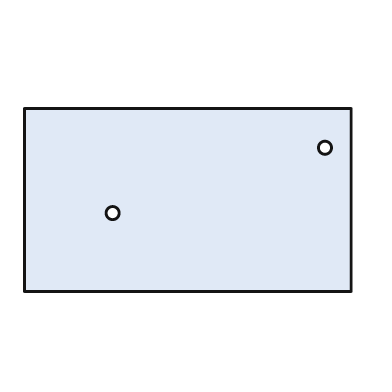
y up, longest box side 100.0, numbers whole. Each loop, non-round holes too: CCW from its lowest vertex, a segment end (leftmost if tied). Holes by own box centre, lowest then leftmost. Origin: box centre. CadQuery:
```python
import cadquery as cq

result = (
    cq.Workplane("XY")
    .moveTo(-50.0, -28.0)
    .lineTo(50.0, -28.0)
    .lineTo(50.0, 28.0)
    .lineTo(-50.0, 28.0)
    .close()
    .moveTo(-23.0, -4.0)
    .circle(2.0)
    .moveTo(42.0, 16.0)
    .circle(2.0)
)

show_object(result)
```